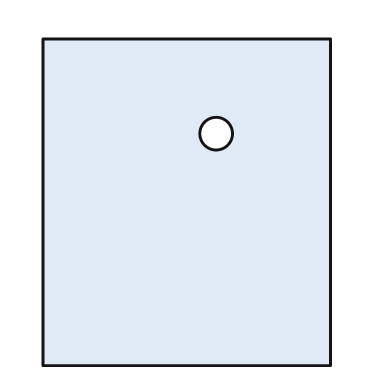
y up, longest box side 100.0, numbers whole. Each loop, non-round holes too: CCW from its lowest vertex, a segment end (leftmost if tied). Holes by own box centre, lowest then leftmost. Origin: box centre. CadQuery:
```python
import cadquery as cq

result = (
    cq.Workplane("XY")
    .moveTo(-44.0, -50.0)
    .lineTo(44.0, -50.0)
    .lineTo(44.0, 50.0)
    .lineTo(-44.0, 50.0)
    .close()
    .moveTo(9.0, 21.0)
    .circle(5.0)
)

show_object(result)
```